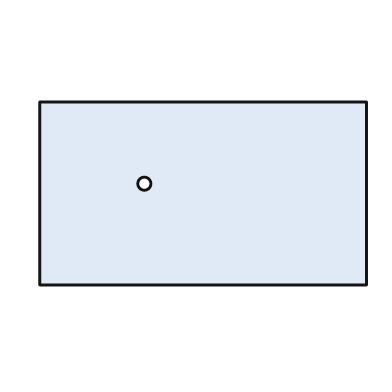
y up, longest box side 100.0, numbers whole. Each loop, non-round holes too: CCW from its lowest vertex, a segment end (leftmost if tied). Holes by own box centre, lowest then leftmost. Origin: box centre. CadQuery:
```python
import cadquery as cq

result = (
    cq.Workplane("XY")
    .moveTo(-50.0, -28.0)
    .lineTo(50.0, -28.0)
    .lineTo(50.0, 28.0)
    .lineTo(-50.0, 28.0)
    .close()
    .moveTo(-18.0, 3.0)
    .circle(2.0)
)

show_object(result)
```